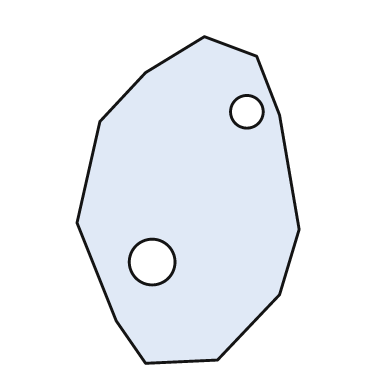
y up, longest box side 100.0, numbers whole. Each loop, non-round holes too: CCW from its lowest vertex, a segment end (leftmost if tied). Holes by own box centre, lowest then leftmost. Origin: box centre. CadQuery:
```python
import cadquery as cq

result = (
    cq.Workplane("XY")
    .moveTo(-13.0, -50.0)
    .lineTo(9.0, -49.0)
    .lineTo(28.0, -29.0)
    .lineTo(34.0, -9.0)
    .lineTo(28.0, 26.0)
    .lineTo(21.0, 44.0)
    .lineTo(5.0, 50.0)
    .lineTo(-13.0, 39.0)
    .lineTo(-27.0, 24.0)
    .lineTo(-34.0, -7.0)
    .lineTo(-22.0, -37.0)
    .close()
    .moveTo(-11.0, -19.0)
    .circle(7.0)
    .moveTo(18.0, 27.0)
    .circle(5.0)
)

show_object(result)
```